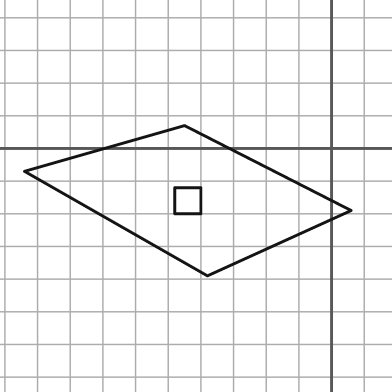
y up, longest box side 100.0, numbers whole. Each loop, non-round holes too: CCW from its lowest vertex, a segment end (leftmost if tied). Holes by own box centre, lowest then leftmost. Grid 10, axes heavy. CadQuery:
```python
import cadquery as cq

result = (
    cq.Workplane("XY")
    .moveTo(-38.0, -39.0)
    .lineTo(6.0, -19.0)
    .lineTo(-45.0, 7.0)
    .lineTo(-94.0, -7.0)
    .close()
    .moveTo(-48.0, -20.0)
    .lineTo(-40.0, -20.0)
    .lineTo(-40.0, -12.0)
    .lineTo(-48.0, -12.0)
    .close()
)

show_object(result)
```